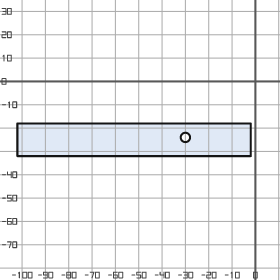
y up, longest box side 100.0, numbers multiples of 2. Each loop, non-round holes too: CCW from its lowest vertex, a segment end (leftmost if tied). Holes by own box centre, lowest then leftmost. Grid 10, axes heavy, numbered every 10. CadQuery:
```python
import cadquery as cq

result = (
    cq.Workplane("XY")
    .moveTo(-102.0, -32.0)
    .lineTo(-2.0, -32.0)
    .lineTo(-2.0, -18.0)
    .lineTo(-102.0, -18.0)
    .close()
    .moveTo(-30.0, -24.0)
    .circle(2.0)
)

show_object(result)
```